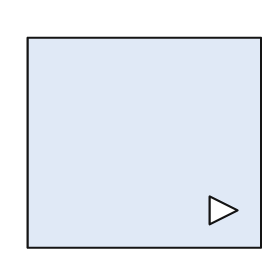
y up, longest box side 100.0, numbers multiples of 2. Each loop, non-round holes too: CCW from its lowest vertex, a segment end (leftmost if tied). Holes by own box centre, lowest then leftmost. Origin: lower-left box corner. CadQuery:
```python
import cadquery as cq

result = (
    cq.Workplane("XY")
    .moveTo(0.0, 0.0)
    .lineTo(100.0, 0.0)
    .lineTo(100.0, 90.0)
    .lineTo(0.0, 90.0)
    .close()
    .moveTo(78.0, 10.0)
    .lineTo(90.0, 16.0)
    .lineTo(78.0, 22.0)
    .close()
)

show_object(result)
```